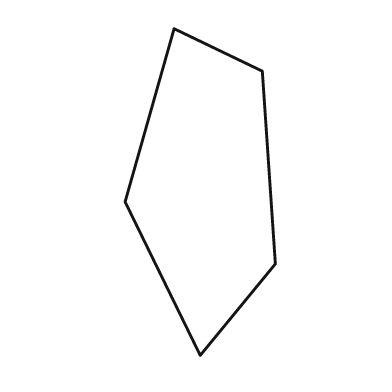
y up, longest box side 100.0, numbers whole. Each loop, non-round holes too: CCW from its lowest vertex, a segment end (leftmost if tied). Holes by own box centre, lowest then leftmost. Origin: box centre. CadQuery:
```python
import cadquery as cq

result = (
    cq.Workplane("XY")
    .moveTo(0.0, -50.0)
    .lineTo(23.0, -22.0)
    .lineTo(19.0, 37.0)
    .lineTo(-8.0, 50.0)
    .lineTo(-23.0, -3.0)
    .close()
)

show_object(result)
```